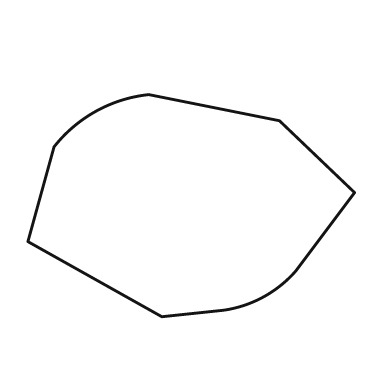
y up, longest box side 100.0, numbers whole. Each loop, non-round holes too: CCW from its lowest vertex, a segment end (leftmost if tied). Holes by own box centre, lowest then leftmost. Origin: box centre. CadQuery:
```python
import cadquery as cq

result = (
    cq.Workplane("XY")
    .moveTo(-9.0, -34.0)
    .lineTo(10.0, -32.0)
    .threePointArc((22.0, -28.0), (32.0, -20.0))
    .lineTo(50.0, 4.0)
    .lineTo(27.0, 26.0)
    .lineTo(-13.0, 34.0)
    .threePointArc((-29.0, 29.0), (-42.0, 18.0))
    .lineTo(-50.0, -11.0)
    .close()
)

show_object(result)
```